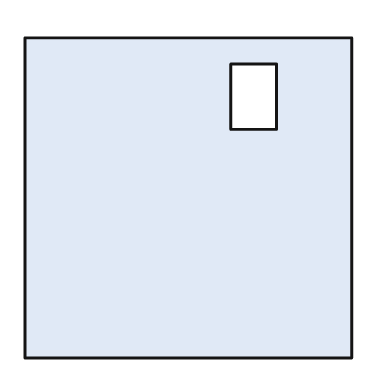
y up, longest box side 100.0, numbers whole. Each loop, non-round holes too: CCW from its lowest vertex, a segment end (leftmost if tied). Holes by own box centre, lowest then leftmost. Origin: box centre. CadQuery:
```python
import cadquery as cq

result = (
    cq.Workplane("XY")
    .moveTo(-50.0, -49.0)
    .lineTo(50.0, -49.0)
    .lineTo(50.0, 49.0)
    .lineTo(-50.0, 49.0)
    .close()
    .moveTo(13.0, 21.0)
    .lineTo(27.0, 21.0)
    .lineTo(27.0, 41.0)
    .lineTo(13.0, 41.0)
    .close()
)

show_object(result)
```